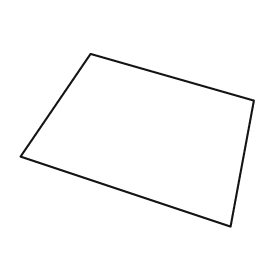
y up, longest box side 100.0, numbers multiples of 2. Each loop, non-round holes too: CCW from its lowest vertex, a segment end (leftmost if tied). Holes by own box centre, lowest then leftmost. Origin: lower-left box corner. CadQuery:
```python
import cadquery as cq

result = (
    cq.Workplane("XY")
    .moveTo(90.0, 0.0)
    .lineTo(100.0, 54.0)
    .lineTo(30.0, 74.0)
    .lineTo(0.0, 30.0)
    .close()
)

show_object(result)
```